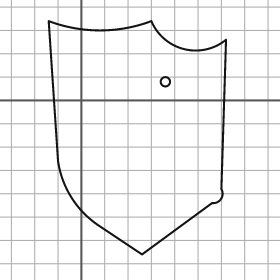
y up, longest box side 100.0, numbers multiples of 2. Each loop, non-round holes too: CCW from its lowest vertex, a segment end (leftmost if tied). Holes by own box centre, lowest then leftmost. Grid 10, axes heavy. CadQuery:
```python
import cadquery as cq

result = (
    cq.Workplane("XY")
    .moveTo(26.0, -66.0)
    .lineTo(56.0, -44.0)
    .threePointArc((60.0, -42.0), (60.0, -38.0))
    .lineTo(62.0, 26.0)
    .threePointArc((44.0, 22.0), (30.0, 34.0))
    .threePointArc((8.0, 30.0), (-14.0, 34.0))
    .lineTo(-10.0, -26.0)
    .threePointArc((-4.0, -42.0), (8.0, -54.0))
    .close()
    .moveTo(36.0, 8.0)
    .circle(2.0)
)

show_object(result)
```